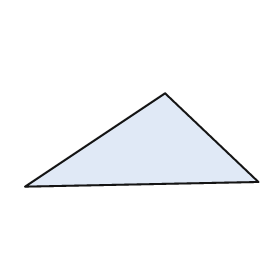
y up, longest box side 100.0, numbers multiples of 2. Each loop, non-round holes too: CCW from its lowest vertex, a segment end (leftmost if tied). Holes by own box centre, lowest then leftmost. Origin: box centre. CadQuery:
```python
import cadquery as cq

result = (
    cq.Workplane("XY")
    .moveTo(-50.0, -20.0)
    .lineTo(50.0, -18.0)
    .lineTo(10.0, 20.0)
    .close()
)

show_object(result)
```